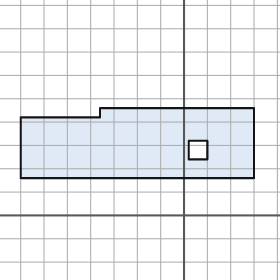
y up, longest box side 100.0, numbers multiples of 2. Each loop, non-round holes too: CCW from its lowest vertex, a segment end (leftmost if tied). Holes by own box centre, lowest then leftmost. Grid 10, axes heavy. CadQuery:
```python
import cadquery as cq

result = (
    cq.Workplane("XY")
    .moveTo(-70.0, 16.0)
    .lineTo(30.0, 16.0)
    .lineTo(30.0, 46.0)
    .lineTo(-36.0, 46.0)
    .lineTo(-36.0, 42.0)
    .lineTo(-70.0, 42.0)
    .close()
    .moveTo(2.0, 24.0)
    .lineTo(10.0, 24.0)
    .lineTo(10.0, 32.0)
    .lineTo(2.0, 32.0)
    .close()
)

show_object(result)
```